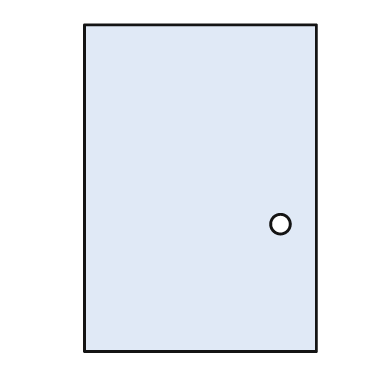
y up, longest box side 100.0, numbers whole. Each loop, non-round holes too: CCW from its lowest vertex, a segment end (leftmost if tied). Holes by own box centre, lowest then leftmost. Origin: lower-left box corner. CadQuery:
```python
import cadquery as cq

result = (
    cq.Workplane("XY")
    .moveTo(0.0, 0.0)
    .lineTo(71.0, 0.0)
    .lineTo(71.0, 100.0)
    .lineTo(0.0, 100.0)
    .close()
    .moveTo(60.0, 39.0)
    .circle(3.0)
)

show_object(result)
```